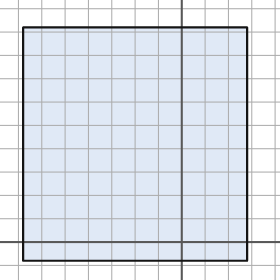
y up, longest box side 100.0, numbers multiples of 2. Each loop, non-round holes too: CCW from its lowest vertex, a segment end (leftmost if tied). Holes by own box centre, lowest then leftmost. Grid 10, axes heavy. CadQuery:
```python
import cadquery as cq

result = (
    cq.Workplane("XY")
    .moveTo(-68.0, -8.0)
    .lineTo(28.0, -8.0)
    .lineTo(28.0, 92.0)
    .lineTo(-68.0, 92.0)
    .close()
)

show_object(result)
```